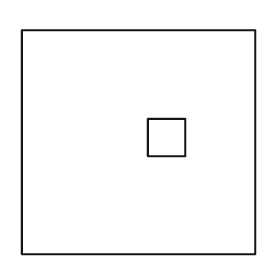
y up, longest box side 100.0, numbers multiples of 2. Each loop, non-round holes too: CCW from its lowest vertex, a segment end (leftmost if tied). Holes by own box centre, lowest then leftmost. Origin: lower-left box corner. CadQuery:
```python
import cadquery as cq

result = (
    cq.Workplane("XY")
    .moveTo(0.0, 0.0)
    .lineTo(100.0, 0.0)
    .lineTo(100.0, 96.0)
    .lineTo(0.0, 96.0)
    .close()
    .moveTo(54.0, 42.0)
    .lineTo(70.0, 42.0)
    .lineTo(70.0, 58.0)
    .lineTo(54.0, 58.0)
    .close()
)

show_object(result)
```